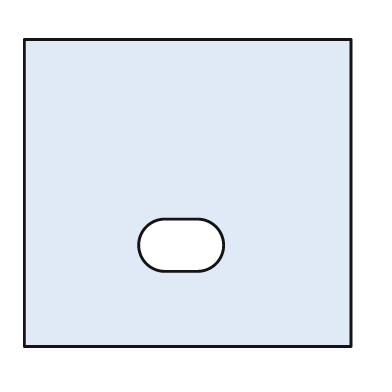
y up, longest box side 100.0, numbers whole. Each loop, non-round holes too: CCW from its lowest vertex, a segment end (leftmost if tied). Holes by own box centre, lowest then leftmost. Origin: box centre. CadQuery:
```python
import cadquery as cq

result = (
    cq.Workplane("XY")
    .moveTo(-50.0, -47.0)
    .lineTo(50.0, -47.0)
    .lineTo(50.0, 47.0)
    .lineTo(-50.0, 47.0)
    .close()
    .moveTo(-7.0, -24.0)
    .lineTo(3.0, -24.0)
    .threePointArc((11.0, -16.0), (3.0, -8.0))
    .lineTo(-7.0, -8.0)
    .threePointArc((-15.0, -16.0), (-7.0, -24.0))
    .close()
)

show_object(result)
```